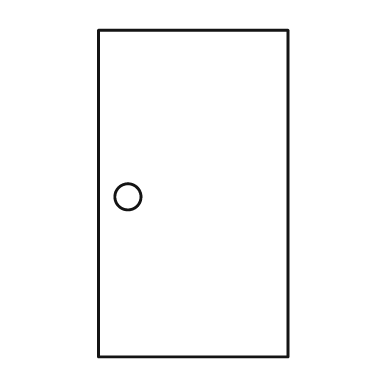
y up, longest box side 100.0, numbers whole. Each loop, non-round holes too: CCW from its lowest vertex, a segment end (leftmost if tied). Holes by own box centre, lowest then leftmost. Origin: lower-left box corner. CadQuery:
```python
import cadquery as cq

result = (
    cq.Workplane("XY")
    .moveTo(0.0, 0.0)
    .lineTo(58.0, 0.0)
    .lineTo(58.0, 100.0)
    .lineTo(0.0, 100.0)
    .close()
    .moveTo(9.0, 49.0)
    .circle(4.0)
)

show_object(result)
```